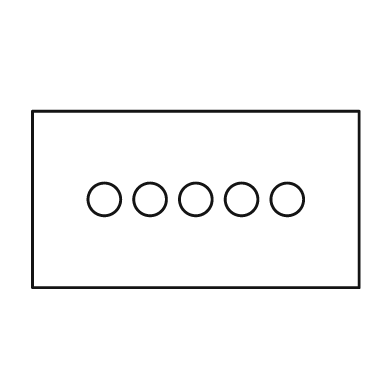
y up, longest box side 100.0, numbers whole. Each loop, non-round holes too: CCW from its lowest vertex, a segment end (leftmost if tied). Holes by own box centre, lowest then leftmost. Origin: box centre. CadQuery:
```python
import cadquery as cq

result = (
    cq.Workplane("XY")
    .moveTo(-50.0, -27.0)
    .lineTo(50.0, -27.0)
    .lineTo(50.0, 27.0)
    .lineTo(-50.0, 27.0)
    .close()
    .moveTo(-28.0, 0.0)
    .circle(5.0)
    .moveTo(-14.0, 0.0)
    .circle(5.0)
    .moveTo(0.0, 0.0)
    .circle(5.0)
    .moveTo(14.0, 0.0)
    .circle(5.0)
    .moveTo(28.0, 0.0)
    .circle(5.0)
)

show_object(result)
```